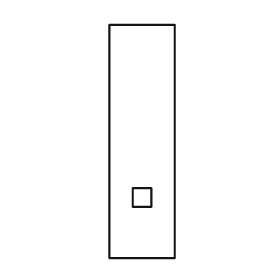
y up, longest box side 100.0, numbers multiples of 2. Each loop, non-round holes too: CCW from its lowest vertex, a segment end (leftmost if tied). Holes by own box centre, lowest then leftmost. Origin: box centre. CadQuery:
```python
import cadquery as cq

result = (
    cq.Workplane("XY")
    .moveTo(-14.0, -50.0)
    .lineTo(14.0, -50.0)
    .lineTo(14.0, 50.0)
    .lineTo(-14.0, 50.0)
    .close()
    .moveTo(-4.0, -28.0)
    .lineTo(4.0, -28.0)
    .lineTo(4.0, -20.0)
    .lineTo(-4.0, -20.0)
    .close()
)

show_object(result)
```